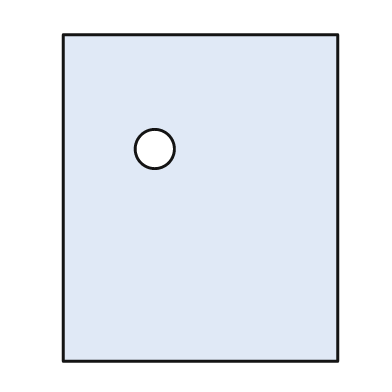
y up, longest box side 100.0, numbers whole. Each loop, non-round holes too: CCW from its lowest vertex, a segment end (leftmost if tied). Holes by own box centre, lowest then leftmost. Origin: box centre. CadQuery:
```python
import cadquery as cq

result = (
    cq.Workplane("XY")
    .moveTo(-42.0, -50.0)
    .lineTo(42.0, -50.0)
    .lineTo(42.0, 50.0)
    .lineTo(-42.0, 50.0)
    .close()
    .moveTo(-14.0, 15.0)
    .circle(6.0)
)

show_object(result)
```